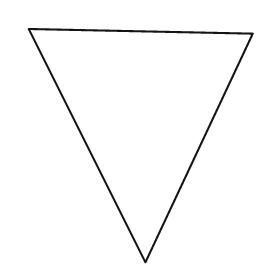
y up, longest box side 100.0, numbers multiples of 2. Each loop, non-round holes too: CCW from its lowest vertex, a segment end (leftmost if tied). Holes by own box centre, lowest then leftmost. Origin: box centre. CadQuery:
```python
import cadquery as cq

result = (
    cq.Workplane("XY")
    .moveTo(2.0, -50.0)
    .lineTo(48.0, 48.0)
    .lineTo(-48.0, 50.0)
    .close()
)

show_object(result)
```